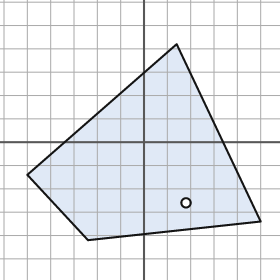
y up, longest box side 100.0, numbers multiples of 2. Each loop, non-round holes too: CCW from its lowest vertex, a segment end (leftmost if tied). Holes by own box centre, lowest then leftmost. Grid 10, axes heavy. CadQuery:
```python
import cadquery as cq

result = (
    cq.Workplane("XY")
    .moveTo(-24.0, -42.0)
    .lineTo(50.0, -34.0)
    .lineTo(14.0, 42.0)
    .lineTo(-50.0, -14.0)
    .close()
    .moveTo(18.0, -26.0)
    .circle(2.0)
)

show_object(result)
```